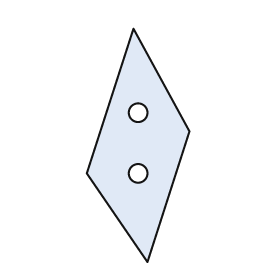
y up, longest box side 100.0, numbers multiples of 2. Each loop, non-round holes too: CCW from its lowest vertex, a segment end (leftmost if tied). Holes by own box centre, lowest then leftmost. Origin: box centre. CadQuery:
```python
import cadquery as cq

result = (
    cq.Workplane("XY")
    .moveTo(4.0, -50.0)
    .lineTo(22.0, 6.0)
    .lineTo(-2.0, 50.0)
    .lineTo(-22.0, -12.0)
    .close()
    .moveTo(0.0, -12.0)
    .circle(4.0)
    .moveTo(0.0, 14.0)
    .circle(4.0)
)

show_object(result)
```